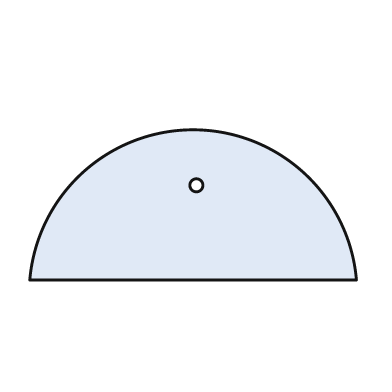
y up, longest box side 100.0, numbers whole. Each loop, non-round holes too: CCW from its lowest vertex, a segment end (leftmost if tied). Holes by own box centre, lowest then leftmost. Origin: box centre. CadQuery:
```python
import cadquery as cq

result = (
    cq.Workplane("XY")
    .moveTo(-50.0, -23.0)
    .lineTo(50.0, -23.0)
    .threePointArc((0.0, 23.0), (-50.0, -23.0))
    .close()
    .moveTo(1.0, 6.0)
    .circle(2.0)
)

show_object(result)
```